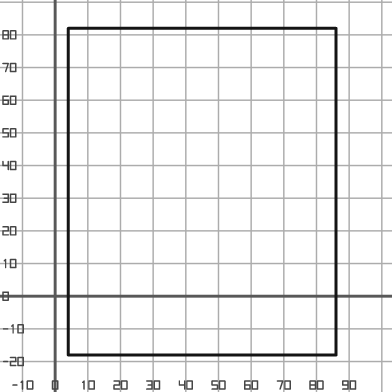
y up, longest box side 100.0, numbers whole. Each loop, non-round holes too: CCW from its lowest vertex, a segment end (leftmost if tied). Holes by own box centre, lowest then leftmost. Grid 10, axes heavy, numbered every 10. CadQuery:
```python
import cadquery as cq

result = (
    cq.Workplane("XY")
    .moveTo(4.0, -18.0)
    .lineTo(86.0, -18.0)
    .lineTo(86.0, 82.0)
    .lineTo(4.0, 82.0)
    .close()
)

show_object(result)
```